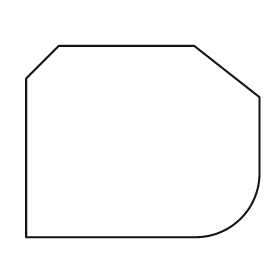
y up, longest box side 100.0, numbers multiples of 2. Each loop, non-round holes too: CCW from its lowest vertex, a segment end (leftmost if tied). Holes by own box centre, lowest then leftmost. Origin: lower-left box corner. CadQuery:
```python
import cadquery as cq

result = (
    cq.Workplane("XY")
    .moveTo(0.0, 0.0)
    .lineTo(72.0, 0.0)
    .threePointArc((92.0, 8.0), (100.0, 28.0))
    .lineTo(100.0, 60.0)
    .lineTo(72.0, 82.0)
    .lineTo(14.0, 82.0)
    .lineTo(0.0, 68.0)
    .close()
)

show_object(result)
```